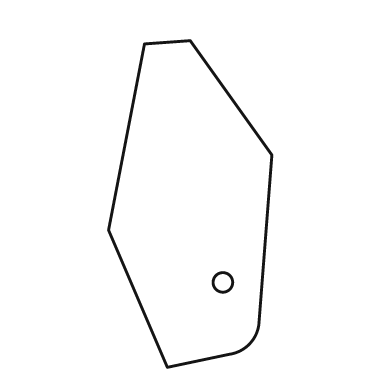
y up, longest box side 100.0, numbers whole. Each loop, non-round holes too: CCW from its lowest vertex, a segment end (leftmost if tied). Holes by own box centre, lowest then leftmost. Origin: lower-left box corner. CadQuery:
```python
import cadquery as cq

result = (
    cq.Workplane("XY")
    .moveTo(18.0, 0.0)
    .lineTo(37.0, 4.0)
    .threePointArc((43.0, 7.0), (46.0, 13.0))
    .lineTo(50.0, 65.0)
    .lineTo(25.0, 100.0)
    .lineTo(11.0, 99.0)
    .lineTo(0.0, 42.0)
    .close()
    .moveTo(35.0, 26.0)
    .circle(3.0)
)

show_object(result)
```